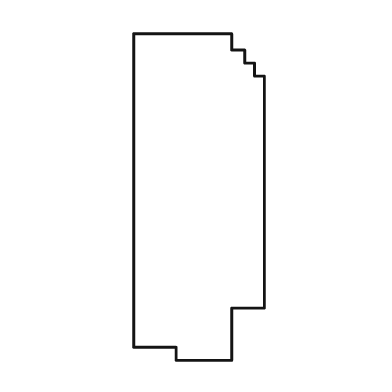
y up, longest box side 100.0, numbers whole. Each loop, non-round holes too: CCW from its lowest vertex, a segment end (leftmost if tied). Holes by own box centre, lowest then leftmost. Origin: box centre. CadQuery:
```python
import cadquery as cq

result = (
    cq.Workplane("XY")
    .moveTo(-7.0, -50.0)
    .lineTo(10.0, -50.0)
    .lineTo(10.0, -34.0)
    .lineTo(20.0, -34.0)
    .lineTo(20.0, 37.0)
    .lineTo(17.0, 37.0)
    .lineTo(17.0, 41.0)
    .lineTo(14.0, 41.0)
    .lineTo(14.0, 45.0)
    .lineTo(10.0, 45.0)
    .lineTo(10.0, 50.0)
    .lineTo(-20.0, 50.0)
    .lineTo(-20.0, -46.0)
    .lineTo(-7.0, -46.0)
    .close()
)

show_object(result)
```